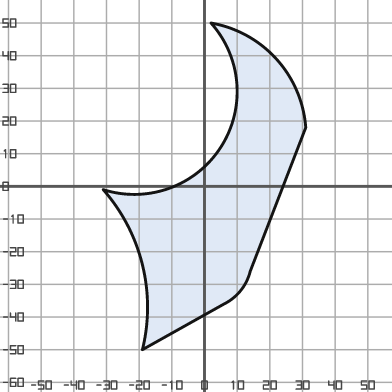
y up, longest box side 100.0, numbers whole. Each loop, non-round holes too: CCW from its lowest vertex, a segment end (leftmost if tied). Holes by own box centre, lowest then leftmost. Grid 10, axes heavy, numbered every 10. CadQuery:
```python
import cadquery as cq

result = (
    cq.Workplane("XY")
    .moveTo(-19.0, -50.0)
    .lineTo(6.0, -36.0)
    .threePointArc((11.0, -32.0), (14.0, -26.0))
    .lineTo(31.0, 18.0)
    .threePointArc((22.0, 39.0), (2.0, 50.0))
    .threePointArc((5.0, 12.0), (-31.0, -1.0))
    .threePointArc((-19.0, -24.0), (-19.0, -50.0))
    .close()
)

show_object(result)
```